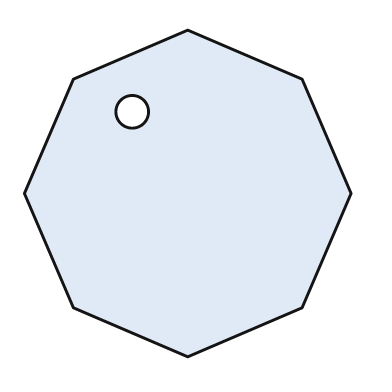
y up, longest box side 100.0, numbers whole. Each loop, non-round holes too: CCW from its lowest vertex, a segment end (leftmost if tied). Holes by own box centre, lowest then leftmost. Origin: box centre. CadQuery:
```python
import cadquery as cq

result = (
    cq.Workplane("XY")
    .moveTo(0.0, -50.0)
    .lineTo(35.0, -35.0)
    .lineTo(50.0, 0.0)
    .lineTo(35.0, 35.0)
    .lineTo(0.0, 50.0)
    .lineTo(-35.0, 35.0)
    .lineTo(-50.0, 0.0)
    .lineTo(-35.0, -35.0)
    .close()
    .moveTo(-17.0, 25.0)
    .circle(5.0)
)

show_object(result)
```